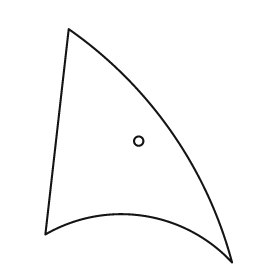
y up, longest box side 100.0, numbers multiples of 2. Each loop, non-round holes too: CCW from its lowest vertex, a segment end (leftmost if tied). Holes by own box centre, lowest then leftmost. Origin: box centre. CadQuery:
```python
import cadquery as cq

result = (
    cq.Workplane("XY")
    .moveTo(40.0, -50.0)
    .threePointArc((14.0, 6.0), (-30.0, 50.0))
    .lineTo(-40.0, -38.0)
    .threePointArc((2.0, -30.0), (40.0, -50.0))
    .close()
    .moveTo(0.0, 2.0)
    .circle(2.0)
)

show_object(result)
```